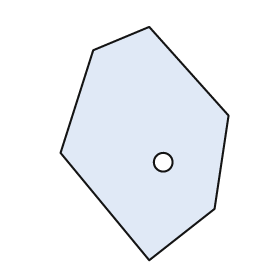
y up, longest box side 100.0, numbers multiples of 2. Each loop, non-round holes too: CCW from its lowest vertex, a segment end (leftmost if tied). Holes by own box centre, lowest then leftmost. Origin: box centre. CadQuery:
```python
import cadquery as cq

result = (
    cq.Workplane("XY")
    .moveTo(2.0, -50.0)
    .lineTo(30.0, -28.0)
    .lineTo(36.0, 12.0)
    .lineTo(2.0, 50.0)
    .lineTo(-22.0, 40.0)
    .lineTo(-36.0, -4.0)
    .close()
    .moveTo(8.0, -8.0)
    .circle(4.0)
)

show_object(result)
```